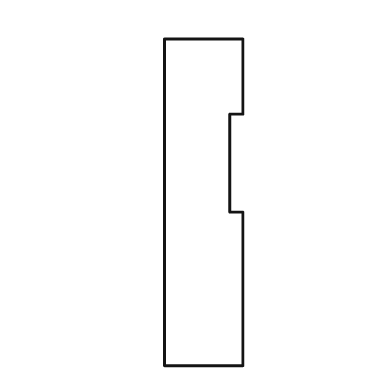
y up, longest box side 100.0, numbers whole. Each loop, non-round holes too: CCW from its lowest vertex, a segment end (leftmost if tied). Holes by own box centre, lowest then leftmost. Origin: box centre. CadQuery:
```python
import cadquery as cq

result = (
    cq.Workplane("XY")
    .moveTo(-12.0, -50.0)
    .lineTo(12.0, -50.0)
    .lineTo(12.0, -3.0)
    .lineTo(8.0, -3.0)
    .lineTo(8.0, 27.0)
    .lineTo(12.0, 27.0)
    .lineTo(12.0, 50.0)
    .lineTo(-12.0, 50.0)
    .close()
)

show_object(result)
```